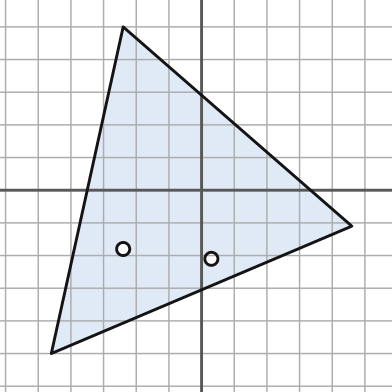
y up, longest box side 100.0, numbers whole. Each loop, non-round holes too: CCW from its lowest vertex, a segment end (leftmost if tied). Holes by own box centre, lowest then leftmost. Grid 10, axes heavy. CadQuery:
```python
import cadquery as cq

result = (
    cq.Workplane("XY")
    .moveTo(-46.0, -50.0)
    .lineTo(46.0, -11.0)
    .lineTo(-24.0, 50.0)
    .close()
    .moveTo(3.0, -21.0)
    .circle(2.0)
    .moveTo(-24.0, -18.0)
    .circle(2.0)
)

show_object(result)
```